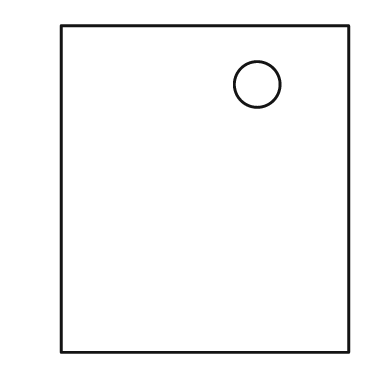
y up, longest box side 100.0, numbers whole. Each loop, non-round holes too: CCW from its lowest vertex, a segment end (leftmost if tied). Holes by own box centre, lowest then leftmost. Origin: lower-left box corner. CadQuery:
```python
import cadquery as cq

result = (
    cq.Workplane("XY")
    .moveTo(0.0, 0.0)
    .lineTo(88.0, 0.0)
    .lineTo(88.0, 100.0)
    .lineTo(0.0, 100.0)
    .close()
    .moveTo(60.0, 82.0)
    .circle(7.0)
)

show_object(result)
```